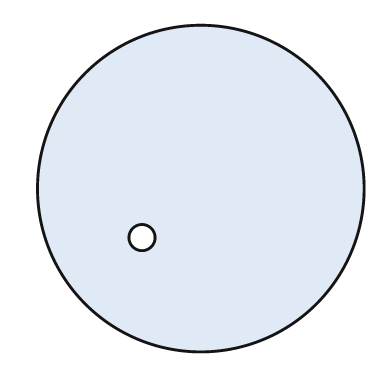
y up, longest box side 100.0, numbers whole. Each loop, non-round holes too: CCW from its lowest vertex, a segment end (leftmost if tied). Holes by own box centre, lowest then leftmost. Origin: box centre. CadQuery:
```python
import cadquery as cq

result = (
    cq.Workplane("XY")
    .moveTo(0.0, 0.0)
    .circle(50.0)
    .moveTo(-18.0, -15.0)
    .circle(4.0)
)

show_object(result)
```